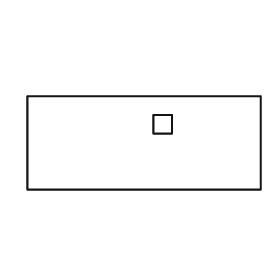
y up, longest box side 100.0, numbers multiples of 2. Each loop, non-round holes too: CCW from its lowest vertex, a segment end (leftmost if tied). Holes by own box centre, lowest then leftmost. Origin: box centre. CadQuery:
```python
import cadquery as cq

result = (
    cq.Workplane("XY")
    .moveTo(-50.0, -20.0)
    .lineTo(50.0, -20.0)
    .lineTo(50.0, 20.0)
    .lineTo(-50.0, 20.0)
    .close()
    .moveTo(4.0, 4.0)
    .lineTo(12.0, 4.0)
    .lineTo(12.0, 12.0)
    .lineTo(4.0, 12.0)
    .close()
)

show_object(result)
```